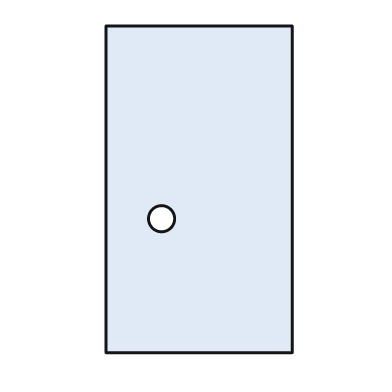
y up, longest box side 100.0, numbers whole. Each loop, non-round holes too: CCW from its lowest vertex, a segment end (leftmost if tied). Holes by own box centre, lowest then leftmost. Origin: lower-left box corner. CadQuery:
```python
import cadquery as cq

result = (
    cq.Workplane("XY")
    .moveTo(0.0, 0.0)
    .lineTo(57.0, 0.0)
    .lineTo(57.0, 100.0)
    .lineTo(0.0, 100.0)
    .close()
    .moveTo(17.0, 41.0)
    .circle(4.0)
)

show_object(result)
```